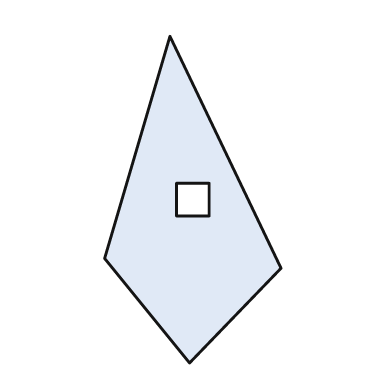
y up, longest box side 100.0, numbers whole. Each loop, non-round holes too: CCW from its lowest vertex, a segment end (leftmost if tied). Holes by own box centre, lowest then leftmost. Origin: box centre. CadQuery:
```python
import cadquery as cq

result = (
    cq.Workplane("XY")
    .moveTo(-1.0, -50.0)
    .lineTo(27.0, -21.0)
    .lineTo(-7.0, 50.0)
    .lineTo(-27.0, -18.0)
    .close()
    .moveTo(-5.0, -5.0)
    .lineTo(5.0, -5.0)
    .lineTo(5.0, 5.0)
    .lineTo(-5.0, 5.0)
    .close()
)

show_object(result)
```